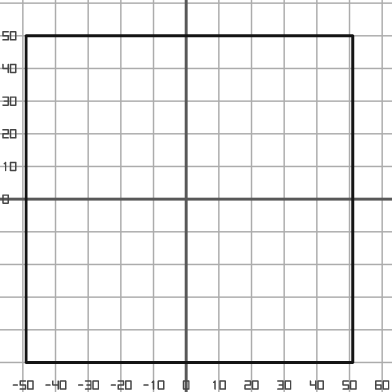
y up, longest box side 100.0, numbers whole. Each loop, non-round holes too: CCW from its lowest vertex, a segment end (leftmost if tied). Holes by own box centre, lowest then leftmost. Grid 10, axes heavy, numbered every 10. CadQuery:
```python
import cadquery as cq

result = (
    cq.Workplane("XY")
    .moveTo(-49.0, -50.0)
    .lineTo(51.0, -50.0)
    .lineTo(51.0, 50.0)
    .lineTo(-49.0, 50.0)
    .close()
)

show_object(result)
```